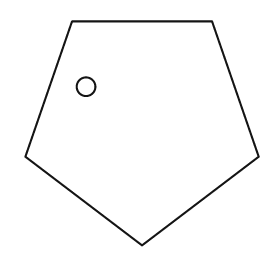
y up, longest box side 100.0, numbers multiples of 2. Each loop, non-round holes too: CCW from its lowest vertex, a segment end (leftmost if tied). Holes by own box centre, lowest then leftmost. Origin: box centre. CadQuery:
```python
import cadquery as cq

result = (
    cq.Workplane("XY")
    .moveTo(0.0, -48.0)
    .lineTo(50.0, -10.0)
    .lineTo(30.0, 48.0)
    .lineTo(-30.0, 48.0)
    .lineTo(-50.0, -10.0)
    .close()
    .moveTo(-24.0, 20.0)
    .circle(4.0)
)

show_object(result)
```